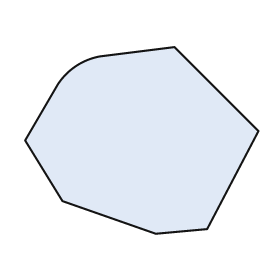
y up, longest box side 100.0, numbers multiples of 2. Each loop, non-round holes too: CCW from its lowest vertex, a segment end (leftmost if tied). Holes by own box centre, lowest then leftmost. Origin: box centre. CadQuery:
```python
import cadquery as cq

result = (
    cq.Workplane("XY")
    .moveTo(6.0, -40.0)
    .lineTo(28.0, -38.0)
    .lineTo(50.0, 4.0)
    .lineTo(14.0, 40.0)
    .lineTo(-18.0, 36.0)
    .threePointArc((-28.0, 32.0), (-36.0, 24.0))
    .lineTo(-50.0, 0.0)
    .lineTo(-34.0, -26.0)
    .close()
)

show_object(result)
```